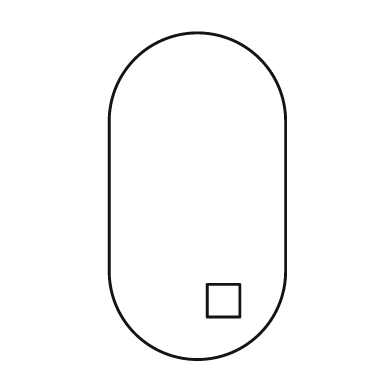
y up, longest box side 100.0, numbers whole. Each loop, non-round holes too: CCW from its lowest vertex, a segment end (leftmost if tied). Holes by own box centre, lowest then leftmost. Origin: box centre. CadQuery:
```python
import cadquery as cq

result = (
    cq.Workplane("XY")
    .moveTo(-27.0, -23.0)
    .threePointArc((0.0, -50.0), (27.0, -23.0))
    .lineTo(27.0, 23.0)
    .threePointArc((0.0, 50.0), (-27.0, 23.0))
    .close()
    .moveTo(3.0, -37.0)
    .lineTo(13.0, -37.0)
    .lineTo(13.0, -27.0)
    .lineTo(3.0, -27.0)
    .close()
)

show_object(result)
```